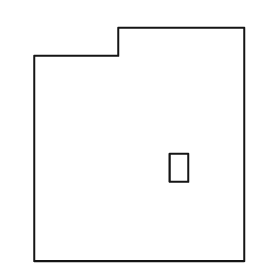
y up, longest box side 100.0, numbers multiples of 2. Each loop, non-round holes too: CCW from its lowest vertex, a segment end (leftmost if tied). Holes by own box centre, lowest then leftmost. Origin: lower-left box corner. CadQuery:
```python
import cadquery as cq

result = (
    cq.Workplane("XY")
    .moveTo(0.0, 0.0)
    .lineTo(90.0, 0.0)
    .lineTo(90.0, 100.0)
    .lineTo(36.0, 100.0)
    .lineTo(36.0, 88.0)
    .lineTo(0.0, 88.0)
    .close()
    .moveTo(58.0, 34.0)
    .lineTo(66.0, 34.0)
    .lineTo(66.0, 46.0)
    .lineTo(58.0, 46.0)
    .close()
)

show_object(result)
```